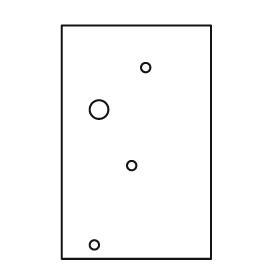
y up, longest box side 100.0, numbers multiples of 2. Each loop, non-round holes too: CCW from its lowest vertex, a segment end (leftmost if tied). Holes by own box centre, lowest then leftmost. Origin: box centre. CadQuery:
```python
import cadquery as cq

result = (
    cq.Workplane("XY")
    .moveTo(-32.0, -50.0)
    .lineTo(32.0, -50.0)
    .lineTo(32.0, 50.0)
    .lineTo(-32.0, 50.0)
    .close()
    .moveTo(-18.0, -44.0)
    .circle(2.0)
    .moveTo(-2.0, -10.0)
    .circle(2.0)
    .moveTo(-16.0, 14.0)
    .circle(4.0)
    .moveTo(4.0, 32.0)
    .circle(2.0)
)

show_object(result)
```